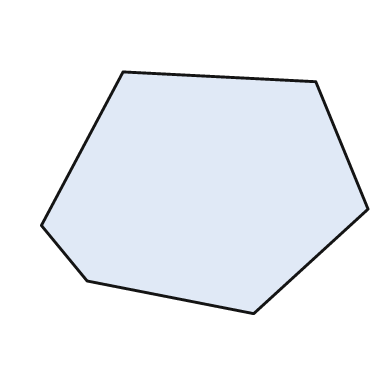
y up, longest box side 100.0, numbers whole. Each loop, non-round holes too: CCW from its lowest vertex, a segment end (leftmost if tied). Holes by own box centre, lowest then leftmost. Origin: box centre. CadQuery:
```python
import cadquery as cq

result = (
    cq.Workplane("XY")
    .moveTo(15.0, -37.0)
    .lineTo(50.0, -5.0)
    .lineTo(34.0, 34.0)
    .lineTo(-25.0, 37.0)
    .lineTo(-50.0, -10.0)
    .lineTo(-36.0, -27.0)
    .close()
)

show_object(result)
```